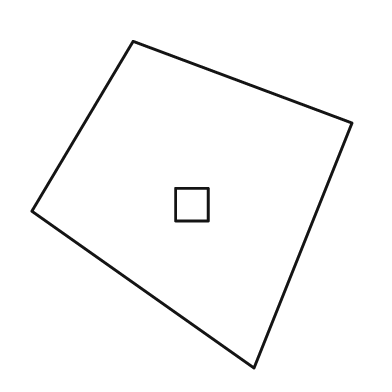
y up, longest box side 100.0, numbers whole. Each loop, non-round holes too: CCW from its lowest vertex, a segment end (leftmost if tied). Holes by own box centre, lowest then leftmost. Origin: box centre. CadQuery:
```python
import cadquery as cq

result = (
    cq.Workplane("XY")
    .moveTo(19.0, -50.0)
    .lineTo(49.0, 25.0)
    .lineTo(-18.0, 50.0)
    .lineTo(-49.0, -2.0)
    .close()
    .moveTo(-5.0, -5.0)
    .lineTo(5.0, -5.0)
    .lineTo(5.0, 5.0)
    .lineTo(-5.0, 5.0)
    .close()
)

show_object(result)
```